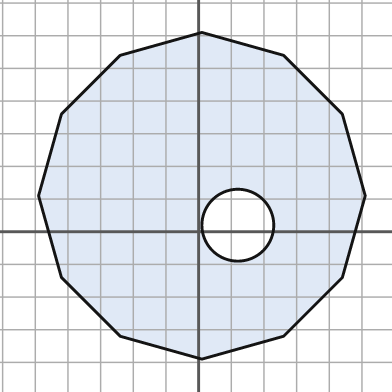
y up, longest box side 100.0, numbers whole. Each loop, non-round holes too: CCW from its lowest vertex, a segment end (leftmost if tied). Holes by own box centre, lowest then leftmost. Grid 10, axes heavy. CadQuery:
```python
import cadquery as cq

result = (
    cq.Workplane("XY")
    .moveTo(1.0, -39.0)
    .lineTo(26.0, -32.0)
    .lineTo(44.0, -14.0)
    .lineTo(51.0, 11.0)
    .lineTo(44.0, 36.0)
    .lineTo(26.0, 54.0)
    .lineTo(1.0, 61.0)
    .lineTo(-24.0, 54.0)
    .lineTo(-42.0, 36.0)
    .lineTo(-49.0, 11.0)
    .lineTo(-42.0, -14.0)
    .lineTo(-24.0, -32.0)
    .close()
    .moveTo(12.0, 2.0)
    .circle(11.0)
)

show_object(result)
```